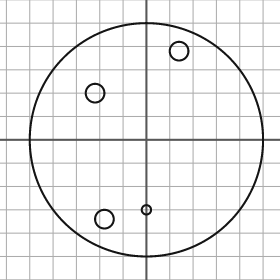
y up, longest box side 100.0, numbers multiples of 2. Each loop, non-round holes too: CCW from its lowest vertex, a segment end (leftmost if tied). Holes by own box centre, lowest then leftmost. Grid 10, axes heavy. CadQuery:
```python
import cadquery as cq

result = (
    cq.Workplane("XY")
    .moveTo(0.0, 0.0)
    .circle(50.0)
    .moveTo(-18.0, -34.0)
    .circle(4.0)
    .moveTo(0.0, -30.0)
    .circle(2.0)
    .moveTo(-22.0, 20.0)
    .circle(4.0)
    .moveTo(14.0, 38.0)
    .circle(4.0)
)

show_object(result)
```